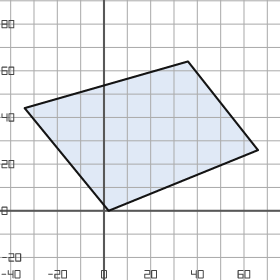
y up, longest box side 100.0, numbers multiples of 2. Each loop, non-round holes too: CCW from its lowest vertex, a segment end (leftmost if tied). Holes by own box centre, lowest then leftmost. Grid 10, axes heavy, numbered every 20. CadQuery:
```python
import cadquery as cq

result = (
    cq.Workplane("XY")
    .moveTo(2.0, 0.0)
    .lineTo(66.0, 26.0)
    .lineTo(36.0, 64.0)
    .lineTo(-34.0, 44.0)
    .close()
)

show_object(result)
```